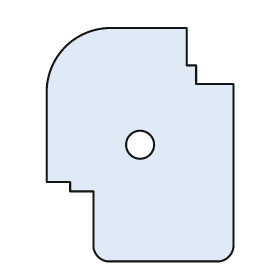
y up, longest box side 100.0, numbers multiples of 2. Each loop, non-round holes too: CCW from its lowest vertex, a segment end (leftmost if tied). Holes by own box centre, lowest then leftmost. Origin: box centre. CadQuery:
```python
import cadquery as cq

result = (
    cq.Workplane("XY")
    .moveTo(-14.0, -50.0)
    .lineTo(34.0, -50.0)
    .threePointArc((38.0, -48.0), (40.0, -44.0))
    .lineTo(40.0, 26.0)
    .lineTo(24.0, 26.0)
    .lineTo(24.0, 34.0)
    .lineTo(20.0, 34.0)
    .lineTo(20.0, 50.0)
    .lineTo(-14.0, 50.0)
    .threePointArc((-32.0, 42.0), (-40.0, 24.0))
    .lineTo(-40.0, -16.0)
    .lineTo(-30.0, -16.0)
    .lineTo(-30.0, -20.0)
    .lineTo(-20.0, -20.0)
    .lineTo(-20.0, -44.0)
    .threePointArc((-18.0, -48.0), (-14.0, -50.0))
    .close()
    .moveTo(0.0, 0.0)
    .circle(6.0)
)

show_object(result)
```